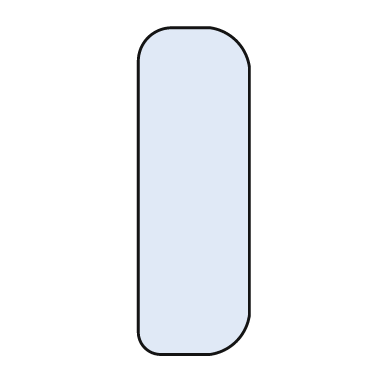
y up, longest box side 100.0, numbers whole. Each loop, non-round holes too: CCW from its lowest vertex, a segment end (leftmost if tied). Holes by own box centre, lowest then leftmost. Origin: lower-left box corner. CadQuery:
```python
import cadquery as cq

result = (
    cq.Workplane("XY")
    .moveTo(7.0, 0.0)
    .lineTo(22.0, 0.0)
    .threePointArc((30.0, 4.0), (34.0, 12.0))
    .lineTo(34.0, 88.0)
    .threePointArc((30.0, 96.0), (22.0, 100.0))
    .lineTo(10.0, 100.0)
    .threePointArc((3.0, 97.0), (0.0, 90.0))
    .lineTo(0.0, 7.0)
    .threePointArc((2.0, 2.0), (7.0, 0.0))
    .close()
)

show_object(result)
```